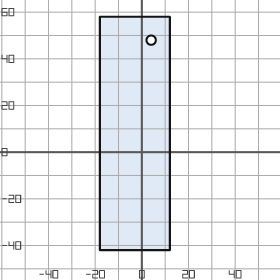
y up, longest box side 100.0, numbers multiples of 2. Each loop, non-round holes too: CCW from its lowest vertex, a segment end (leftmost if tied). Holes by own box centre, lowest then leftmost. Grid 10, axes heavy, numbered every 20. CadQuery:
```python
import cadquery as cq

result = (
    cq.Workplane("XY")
    .moveTo(-18.0, -42.0)
    .lineTo(12.0, -42.0)
    .lineTo(12.0, 58.0)
    .lineTo(-18.0, 58.0)
    .close()
    .moveTo(4.0, 48.0)
    .circle(2.0)
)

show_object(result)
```